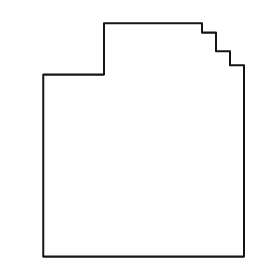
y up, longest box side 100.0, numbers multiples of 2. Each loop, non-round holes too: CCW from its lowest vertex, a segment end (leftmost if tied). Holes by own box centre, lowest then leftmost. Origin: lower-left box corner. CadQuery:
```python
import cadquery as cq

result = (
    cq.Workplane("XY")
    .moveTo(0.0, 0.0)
    .lineTo(86.0, 0.0)
    .lineTo(86.0, 82.0)
    .lineTo(80.0, 82.0)
    .lineTo(80.0, 88.0)
    .lineTo(74.0, 88.0)
    .lineTo(74.0, 96.0)
    .lineTo(68.0, 96.0)
    .lineTo(68.0, 100.0)
    .lineTo(26.0, 100.0)
    .lineTo(26.0, 78.0)
    .lineTo(0.0, 78.0)
    .close()
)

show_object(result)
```